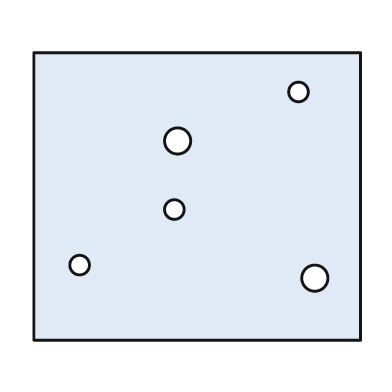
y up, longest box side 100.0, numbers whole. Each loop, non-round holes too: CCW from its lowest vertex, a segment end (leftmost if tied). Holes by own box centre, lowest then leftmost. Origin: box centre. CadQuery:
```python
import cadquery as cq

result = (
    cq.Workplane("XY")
    .moveTo(-50.0, -44.0)
    .lineTo(50.0, -44.0)
    .lineTo(50.0, 44.0)
    .lineTo(-50.0, 44.0)
    .close()
    .moveTo(36.0, -25.0)
    .circle(4.0)
    .moveTo(-36.0, -21.0)
    .circle(3.0)
    .moveTo(-7.0, -4.0)
    .circle(3.0)
    .moveTo(-6.0, 17.0)
    .circle(4.0)
    .moveTo(31.0, 32.0)
    .circle(3.0)
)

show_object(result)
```